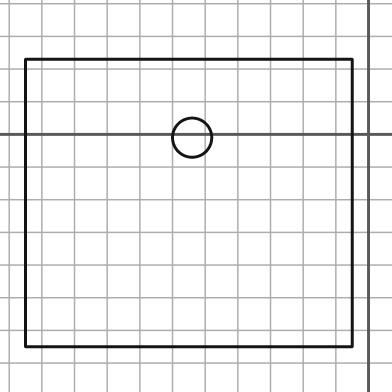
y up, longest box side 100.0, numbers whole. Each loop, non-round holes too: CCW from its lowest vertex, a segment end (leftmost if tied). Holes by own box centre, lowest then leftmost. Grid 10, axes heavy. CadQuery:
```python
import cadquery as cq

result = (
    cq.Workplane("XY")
    .moveTo(-105.0, -65.0)
    .lineTo(-5.0, -65.0)
    .lineTo(-5.0, 23.0)
    .lineTo(-105.0, 23.0)
    .close()
    .moveTo(-54.0, -1.0)
    .circle(6.0)
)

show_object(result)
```